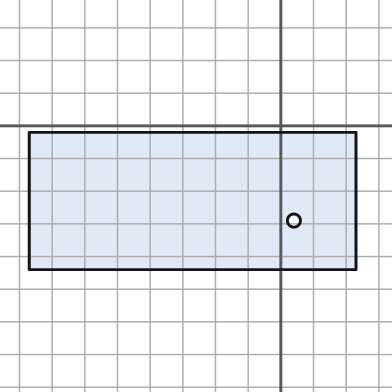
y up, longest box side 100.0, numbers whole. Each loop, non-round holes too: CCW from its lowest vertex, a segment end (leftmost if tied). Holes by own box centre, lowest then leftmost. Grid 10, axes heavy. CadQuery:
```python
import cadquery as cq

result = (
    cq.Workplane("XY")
    .moveTo(-77.0, -44.0)
    .lineTo(23.0, -44.0)
    .lineTo(23.0, -2.0)
    .lineTo(-77.0, -2.0)
    .close()
    .moveTo(4.0, -29.0)
    .circle(2.0)
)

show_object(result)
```